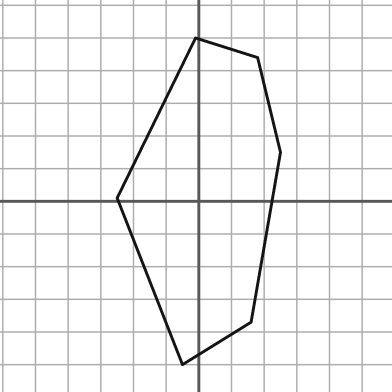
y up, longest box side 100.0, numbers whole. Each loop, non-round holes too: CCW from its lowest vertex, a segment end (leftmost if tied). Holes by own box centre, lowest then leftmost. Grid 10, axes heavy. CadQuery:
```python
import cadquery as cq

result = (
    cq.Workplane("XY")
    .moveTo(-5.0, -50.0)
    .lineTo(16.0, -37.0)
    .lineTo(25.0, 15.0)
    .lineTo(18.0, 44.0)
    .lineTo(-1.0, 50.0)
    .lineTo(-25.0, 1.0)
    .close()
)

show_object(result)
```